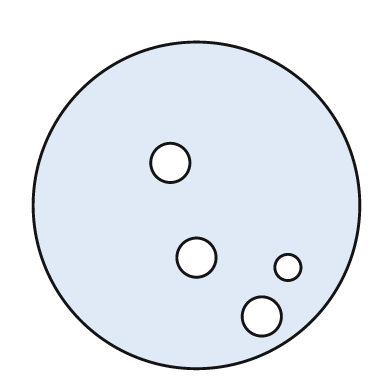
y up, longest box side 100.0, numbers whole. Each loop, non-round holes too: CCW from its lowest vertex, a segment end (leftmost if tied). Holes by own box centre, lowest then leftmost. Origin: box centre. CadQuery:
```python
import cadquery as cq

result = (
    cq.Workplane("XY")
    .moveTo(0.0, 0.0)
    .circle(50.0)
    .moveTo(20.0, -34.0)
    .circle(6.0)
    .moveTo(28.0, -19.0)
    .circle(4.0)
    .moveTo(0.0, -16.0)
    .circle(6.0)
    .moveTo(-8.0, 13.0)
    .circle(6.0)
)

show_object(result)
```